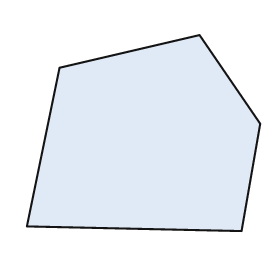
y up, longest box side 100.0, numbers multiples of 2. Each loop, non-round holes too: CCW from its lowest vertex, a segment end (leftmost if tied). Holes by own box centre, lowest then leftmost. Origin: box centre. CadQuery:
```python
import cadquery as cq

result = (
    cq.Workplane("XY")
    .moveTo(42.0, -42.0)
    .lineTo(50.0, 4.0)
    .lineTo(24.0, 42.0)
    .lineTo(-36.0, 28.0)
    .lineTo(-50.0, -40.0)
    .close()
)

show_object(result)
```